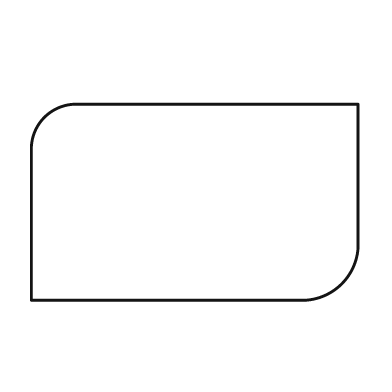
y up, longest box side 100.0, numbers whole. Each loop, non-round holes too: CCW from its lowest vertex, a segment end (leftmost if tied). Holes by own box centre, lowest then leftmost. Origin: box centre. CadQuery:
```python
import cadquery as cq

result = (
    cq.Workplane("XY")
    .moveTo(-50.0, -30.0)
    .lineTo(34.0, -30.0)
    .threePointArc((45.0, -25.0), (50.0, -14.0))
    .lineTo(50.0, 30.0)
    .lineTo(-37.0, 30.0)
    .threePointArc((-46.0, 26.0), (-50.0, 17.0))
    .close()
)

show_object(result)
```